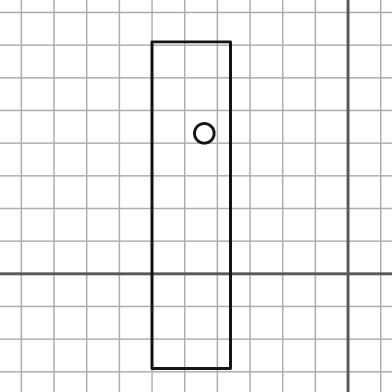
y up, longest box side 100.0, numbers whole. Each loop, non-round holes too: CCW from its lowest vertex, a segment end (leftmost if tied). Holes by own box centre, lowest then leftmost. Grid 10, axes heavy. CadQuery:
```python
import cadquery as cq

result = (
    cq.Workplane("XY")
    .moveTo(-60.0, -29.0)
    .lineTo(-36.0, -29.0)
    .lineTo(-36.0, 71.0)
    .lineTo(-60.0, 71.0)
    .close()
    .moveTo(-44.0, 43.0)
    .circle(3.0)
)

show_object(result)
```